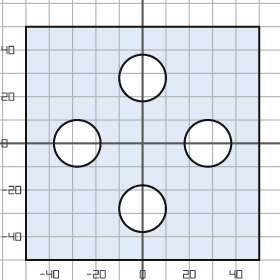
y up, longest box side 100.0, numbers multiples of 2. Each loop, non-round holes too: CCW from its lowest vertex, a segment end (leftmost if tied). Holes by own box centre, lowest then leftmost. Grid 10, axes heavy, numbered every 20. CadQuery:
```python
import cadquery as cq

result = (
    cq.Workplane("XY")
    .moveTo(-50.0, -50.0)
    .lineTo(50.0, -50.0)
    .lineTo(50.0, 50.0)
    .lineTo(-50.0, 50.0)
    .close()
    .moveTo(0.0, -28.0)
    .circle(10.0)
    .moveTo(-28.0, 0.0)
    .circle(10.0)
    .moveTo(28.0, 0.0)
    .circle(10.0)
    .moveTo(0.0, 28.0)
    .circle(10.0)
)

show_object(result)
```